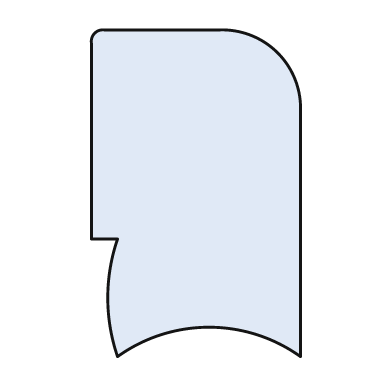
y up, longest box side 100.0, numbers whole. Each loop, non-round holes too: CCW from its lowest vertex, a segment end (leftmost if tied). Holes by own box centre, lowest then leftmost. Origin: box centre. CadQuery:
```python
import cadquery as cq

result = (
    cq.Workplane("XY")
    .moveTo(-24.0, -50.0)
    .threePointArc((4.0, -41.0), (32.0, -50.0))
    .lineTo(32.0, 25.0)
    .threePointArc((25.0, 43.0), (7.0, 50.0))
    .lineTo(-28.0, 50.0)
    .threePointArc((-31.0, 49.0), (-32.0, 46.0))
    .lineTo(-32.0, -14.0)
    .lineTo(-24.0, -14.0)
    .threePointArc((-27.0, -32.0), (-24.0, -50.0))
    .close()
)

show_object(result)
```